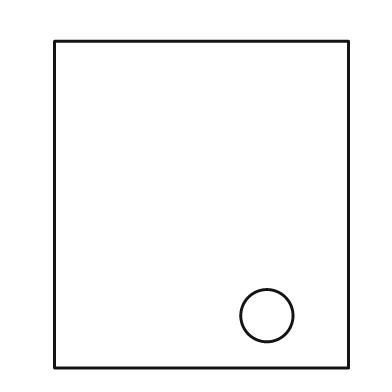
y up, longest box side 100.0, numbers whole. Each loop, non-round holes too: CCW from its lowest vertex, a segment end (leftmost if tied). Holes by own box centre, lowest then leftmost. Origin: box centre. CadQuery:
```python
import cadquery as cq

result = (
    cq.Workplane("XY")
    .moveTo(-45.0, -50.0)
    .lineTo(45.0, -50.0)
    .lineTo(45.0, 50.0)
    .lineTo(-45.0, 50.0)
    .close()
    .moveTo(20.0, -34.0)
    .circle(8.0)
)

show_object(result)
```